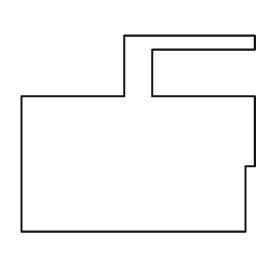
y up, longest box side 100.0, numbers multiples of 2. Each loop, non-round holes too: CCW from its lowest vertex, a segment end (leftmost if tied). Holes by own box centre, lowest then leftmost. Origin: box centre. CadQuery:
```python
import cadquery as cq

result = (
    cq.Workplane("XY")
    .moveTo(-50.0, -42.0)
    .lineTo(46.0, -42.0)
    .lineTo(46.0, -14.0)
    .lineTo(50.0, -14.0)
    .lineTo(50.0, 16.0)
    .lineTo(6.0, 16.0)
    .lineTo(6.0, 36.0)
    .lineTo(50.0, 36.0)
    .lineTo(50.0, 42.0)
    .lineTo(-6.0, 42.0)
    .lineTo(-6.0, 16.0)
    .lineTo(-50.0, 16.0)
    .close()
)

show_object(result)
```